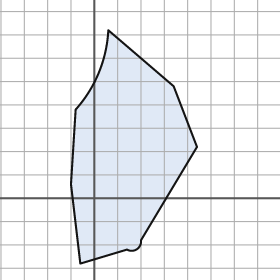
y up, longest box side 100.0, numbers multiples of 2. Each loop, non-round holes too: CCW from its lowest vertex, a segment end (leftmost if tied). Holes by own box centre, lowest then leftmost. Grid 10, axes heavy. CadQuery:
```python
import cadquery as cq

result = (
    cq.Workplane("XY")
    .moveTo(-6.0, -28.0)
    .lineTo(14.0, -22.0)
    .threePointArc((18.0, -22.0), (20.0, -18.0))
    .lineTo(44.0, 22.0)
    .lineTo(34.0, 48.0)
    .lineTo(6.0, 72.0)
    .threePointArc((2.0, 54.0), (-8.0, 38.0))
    .lineTo(-10.0, 6.0)
    .close()
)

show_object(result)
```